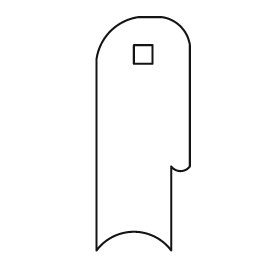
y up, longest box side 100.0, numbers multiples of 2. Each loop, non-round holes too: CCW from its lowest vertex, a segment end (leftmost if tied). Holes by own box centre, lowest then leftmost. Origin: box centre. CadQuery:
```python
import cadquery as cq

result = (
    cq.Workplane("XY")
    .moveTo(-20.0, -50.0)
    .threePointArc((-4.0, -42.0), (12.0, -50.0))
    .lineTo(12.0, -14.0)
    .threePointArc((16.0, -16.0), (20.0, -14.0))
    .lineTo(20.0, 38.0)
    .threePointArc((16.0, 46.0), (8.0, 50.0))
    .lineTo(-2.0, 50.0)
    .threePointArc((-14.0, 44.0), (-20.0, 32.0))
    .close()
    .moveTo(-4.0, 30.0)
    .lineTo(4.0, 30.0)
    .lineTo(4.0, 38.0)
    .lineTo(-4.0, 38.0)
    .close()
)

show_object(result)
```